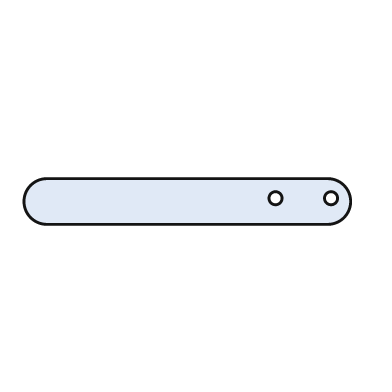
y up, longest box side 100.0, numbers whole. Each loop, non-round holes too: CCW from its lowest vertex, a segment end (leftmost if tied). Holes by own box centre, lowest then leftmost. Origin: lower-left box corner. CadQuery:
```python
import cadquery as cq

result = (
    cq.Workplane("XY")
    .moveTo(7.0, 0.0)
    .lineTo(93.0, 0.0)
    .threePointArc((100.0, 7.0), (93.0, 14.0))
    .lineTo(7.0, 14.0)
    .threePointArc((0.0, 7.0), (7.0, 0.0))
    .close()
    .moveTo(77.0, 8.0)
    .circle(2.0)
    .moveTo(94.0, 8.0)
    .circle(2.0)
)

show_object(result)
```